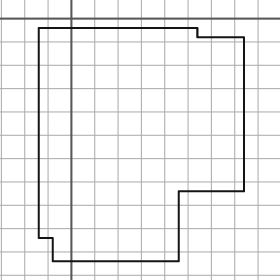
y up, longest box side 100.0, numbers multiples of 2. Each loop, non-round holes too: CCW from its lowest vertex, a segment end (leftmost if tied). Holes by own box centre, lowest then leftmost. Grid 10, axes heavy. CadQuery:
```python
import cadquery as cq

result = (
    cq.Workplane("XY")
    .moveTo(-8.0, -104.0)
    .lineTo(46.0, -104.0)
    .lineTo(46.0, -74.0)
    .lineTo(74.0, -74.0)
    .lineTo(74.0, -8.0)
    .lineTo(54.0, -8.0)
    .lineTo(54.0, -4.0)
    .lineTo(-14.0, -4.0)
    .lineTo(-14.0, -94.0)
    .lineTo(-8.0, -94.0)
    .close()
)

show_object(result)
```